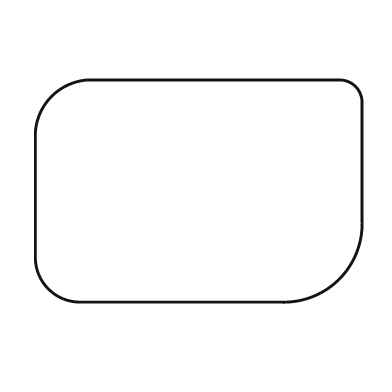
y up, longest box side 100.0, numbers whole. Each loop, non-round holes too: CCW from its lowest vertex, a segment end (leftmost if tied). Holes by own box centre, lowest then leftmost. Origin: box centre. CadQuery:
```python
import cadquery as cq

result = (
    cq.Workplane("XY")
    .moveTo(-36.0, -34.0)
    .lineTo(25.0, -34.0)
    .threePointArc((43.0, -27.0), (50.0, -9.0))
    .lineTo(50.0, 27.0)
    .threePointArc((48.0, 32.0), (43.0, 34.0))
    .lineTo(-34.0, 34.0)
    .threePointArc((-45.0, 29.0), (-50.0, 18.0))
    .lineTo(-50.0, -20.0)
    .threePointArc((-46.0, -30.0), (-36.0, -34.0))
    .close()
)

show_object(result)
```